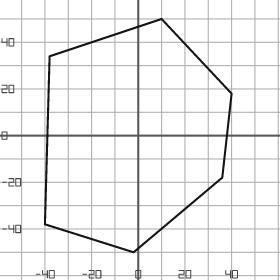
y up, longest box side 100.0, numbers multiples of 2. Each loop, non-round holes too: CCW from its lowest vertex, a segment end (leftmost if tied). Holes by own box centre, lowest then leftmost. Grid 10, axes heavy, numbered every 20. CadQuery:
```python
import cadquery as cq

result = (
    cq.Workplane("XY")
    .moveTo(-2.0, -50.0)
    .lineTo(36.0, -18.0)
    .lineTo(40.0, 18.0)
    .lineTo(10.0, 50.0)
    .lineTo(-38.0, 34.0)
    .lineTo(-40.0, -38.0)
    .close()
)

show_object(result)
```